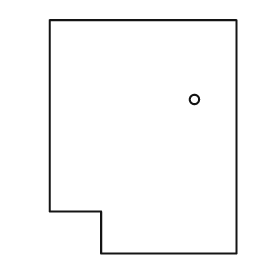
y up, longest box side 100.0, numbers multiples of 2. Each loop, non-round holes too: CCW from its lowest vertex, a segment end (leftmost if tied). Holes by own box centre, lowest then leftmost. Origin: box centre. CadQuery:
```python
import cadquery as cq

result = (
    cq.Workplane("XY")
    .moveTo(-18.0, -50.0)
    .lineTo(40.0, -50.0)
    .lineTo(40.0, 50.0)
    .lineTo(-40.0, 50.0)
    .lineTo(-40.0, -32.0)
    .lineTo(-18.0, -32.0)
    .close()
    .moveTo(22.0, 16.0)
    .circle(2.0)
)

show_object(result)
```